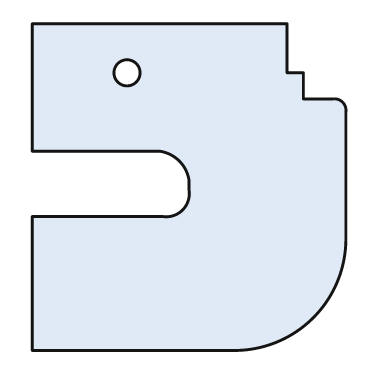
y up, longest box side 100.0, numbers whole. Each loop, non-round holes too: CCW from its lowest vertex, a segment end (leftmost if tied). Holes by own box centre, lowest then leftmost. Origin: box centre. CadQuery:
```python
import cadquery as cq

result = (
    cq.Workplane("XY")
    .moveTo(-48.0, -50.0)
    .lineTo(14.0, -50.0)
    .threePointArc((38.0, -40.0), (48.0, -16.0))
    .lineTo(48.0, 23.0)
    .threePointArc((47.0, 26.0), (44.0, 27.0))
    .lineTo(35.0, 27.0)
    .lineTo(35.0, 35.0)
    .lineTo(30.0, 35.0)
    .lineTo(30.0, 50.0)
    .lineTo(-48.0, 50.0)
    .lineTo(-48.0, 11.0)
    .lineTo(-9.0, 11.0)
    .threePointArc((-3.0, 8.0), (0.0, 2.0))
    .lineTo(0.0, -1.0)
    .threePointArc((-2.0, -7.0), (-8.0, -9.0))
    .lineTo(-48.0, -9.0)
    .close()
    .moveTo(-19.0, 35.0)
    .circle(4.0)
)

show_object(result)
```